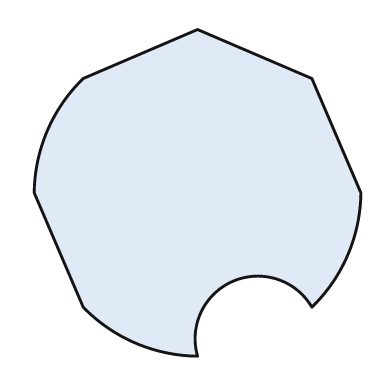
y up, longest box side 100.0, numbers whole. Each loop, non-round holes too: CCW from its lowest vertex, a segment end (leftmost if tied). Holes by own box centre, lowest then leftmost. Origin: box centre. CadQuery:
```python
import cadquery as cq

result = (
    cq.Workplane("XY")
    .moveTo(0.0, -50.0)
    .threePointArc((11.0, -27.0), (35.0, -35.0))
    .threePointArc((46.0, -19.0), (50.0, 0.0))
    .lineTo(35.0, 35.0)
    .lineTo(0.0, 50.0)
    .lineTo(-35.0, 35.0)
    .threePointArc((-46.0, 19.0), (-50.0, 0.0))
    .lineTo(-35.0, -35.0)
    .threePointArc((-19.0, -46.0), (0.0, -50.0))
    .close()
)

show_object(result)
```